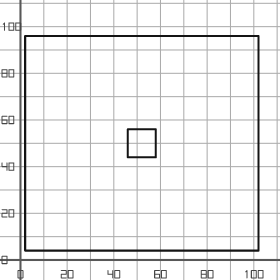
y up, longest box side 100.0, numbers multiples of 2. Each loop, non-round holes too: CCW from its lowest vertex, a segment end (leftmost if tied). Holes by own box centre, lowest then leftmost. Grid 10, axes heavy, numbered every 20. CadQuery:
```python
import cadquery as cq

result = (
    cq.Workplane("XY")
    .moveTo(2.0, 4.0)
    .lineTo(102.0, 4.0)
    .lineTo(102.0, 96.0)
    .lineTo(2.0, 96.0)
    .close()
    .moveTo(46.0, 44.0)
    .lineTo(58.0, 44.0)
    .lineTo(58.0, 56.0)
    .lineTo(46.0, 56.0)
    .close()
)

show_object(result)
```